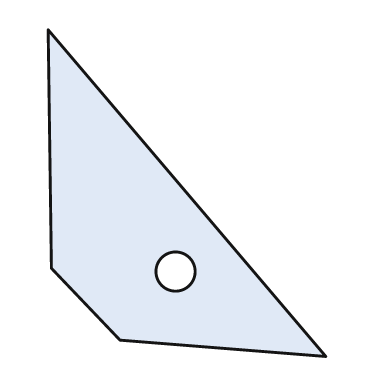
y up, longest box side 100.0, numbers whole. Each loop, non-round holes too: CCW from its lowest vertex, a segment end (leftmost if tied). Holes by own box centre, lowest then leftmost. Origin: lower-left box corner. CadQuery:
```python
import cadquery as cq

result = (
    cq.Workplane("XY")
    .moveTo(85.0, 0.0)
    .lineTo(0.0, 100.0)
    .lineTo(1.0, 27.0)
    .lineTo(22.0, 5.0)
    .close()
    .moveTo(39.0, 26.0)
    .circle(6.0)
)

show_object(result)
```